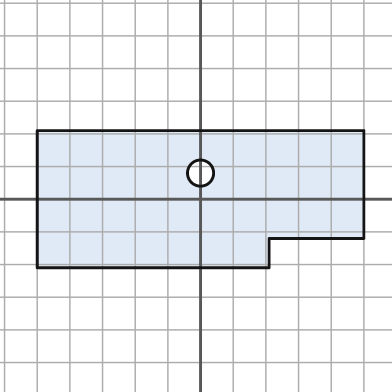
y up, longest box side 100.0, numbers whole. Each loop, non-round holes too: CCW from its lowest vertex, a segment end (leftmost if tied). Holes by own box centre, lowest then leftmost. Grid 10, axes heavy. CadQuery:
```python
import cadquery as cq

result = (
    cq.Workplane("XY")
    .moveTo(-50.0, -21.0)
    .lineTo(21.0, -21.0)
    .lineTo(21.0, -12.0)
    .lineTo(50.0, -12.0)
    .lineTo(50.0, 21.0)
    .lineTo(-50.0, 21.0)
    .close()
    .moveTo(0.0, 8.0)
    .circle(4.0)
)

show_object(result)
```